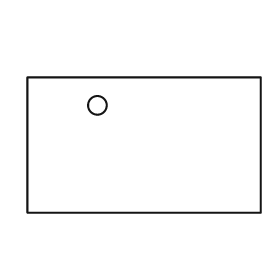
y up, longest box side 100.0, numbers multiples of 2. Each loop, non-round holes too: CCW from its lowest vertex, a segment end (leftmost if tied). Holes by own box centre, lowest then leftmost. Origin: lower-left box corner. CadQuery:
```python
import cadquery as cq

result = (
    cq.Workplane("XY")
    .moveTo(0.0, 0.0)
    .lineTo(100.0, 0.0)
    .lineTo(100.0, 58.0)
    .lineTo(0.0, 58.0)
    .close()
    .moveTo(30.0, 46.0)
    .circle(4.0)
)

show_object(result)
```